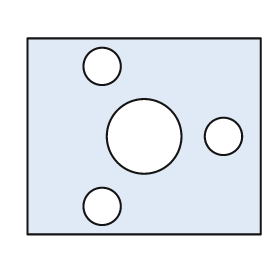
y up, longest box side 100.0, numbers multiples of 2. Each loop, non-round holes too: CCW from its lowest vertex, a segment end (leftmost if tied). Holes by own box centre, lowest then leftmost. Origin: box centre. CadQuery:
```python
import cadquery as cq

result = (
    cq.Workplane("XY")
    .moveTo(-50.0, -42.0)
    .lineTo(50.0, -42.0)
    .lineTo(50.0, 42.0)
    .lineTo(-50.0, 42.0)
    .close()
    .moveTo(-18.0, -30.0)
    .circle(8.0)
    .moveTo(0.0, 0.0)
    .circle(16.0)
    .moveTo(34.0, 0.0)
    .circle(8.0)
    .moveTo(-18.0, 30.0)
    .circle(8.0)
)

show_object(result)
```